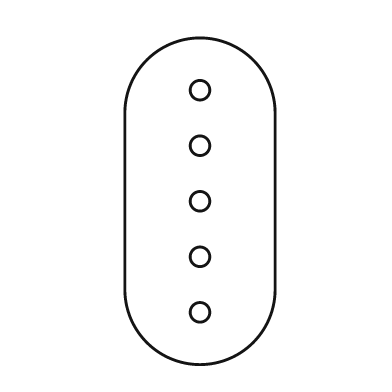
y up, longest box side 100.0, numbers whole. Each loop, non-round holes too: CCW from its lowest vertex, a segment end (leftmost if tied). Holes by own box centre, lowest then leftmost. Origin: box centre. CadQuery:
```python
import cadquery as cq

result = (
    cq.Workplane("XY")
    .moveTo(-23.0, -27.0)
    .threePointArc((0.0, -50.0), (23.0, -27.0))
    .lineTo(23.0, 27.0)
    .threePointArc((0.0, 50.0), (-23.0, 27.0))
    .close()
    .moveTo(0.0, -34.0)
    .circle(3.0)
    .moveTo(0.0, -17.0)
    .circle(3.0)
    .moveTo(0.0, 0.0)
    .circle(3.0)
    .moveTo(0.0, 17.0)
    .circle(3.0)
    .moveTo(0.0, 34.0)
    .circle(3.0)
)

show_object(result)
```